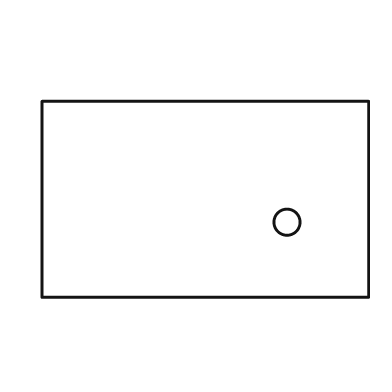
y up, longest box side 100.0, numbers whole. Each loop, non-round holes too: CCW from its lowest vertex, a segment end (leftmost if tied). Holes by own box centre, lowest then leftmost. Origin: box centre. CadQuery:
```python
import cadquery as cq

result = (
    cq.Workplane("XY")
    .moveTo(-50.0, -30.0)
    .lineTo(50.0, -30.0)
    .lineTo(50.0, 30.0)
    .lineTo(-50.0, 30.0)
    .close()
    .moveTo(25.0, -7.0)
    .circle(4.0)
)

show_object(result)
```